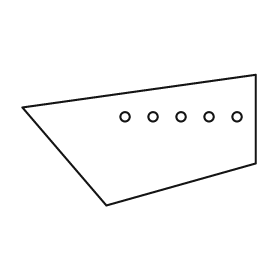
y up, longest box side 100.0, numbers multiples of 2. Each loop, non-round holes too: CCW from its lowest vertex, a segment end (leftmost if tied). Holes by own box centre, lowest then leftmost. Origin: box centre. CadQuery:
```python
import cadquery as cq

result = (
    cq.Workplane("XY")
    .moveTo(-14.0, -28.0)
    .lineTo(50.0, -10.0)
    .lineTo(50.0, 28.0)
    .lineTo(-50.0, 14.0)
    .close()
    .moveTo(-6.0, 10.0)
    .circle(2.0)
    .moveTo(6.0, 10.0)
    .circle(2.0)
    .moveTo(18.0, 10.0)
    .circle(2.0)
    .moveTo(30.0, 10.0)
    .circle(2.0)
    .moveTo(42.0, 10.0)
    .circle(2.0)
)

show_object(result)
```